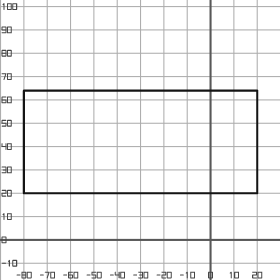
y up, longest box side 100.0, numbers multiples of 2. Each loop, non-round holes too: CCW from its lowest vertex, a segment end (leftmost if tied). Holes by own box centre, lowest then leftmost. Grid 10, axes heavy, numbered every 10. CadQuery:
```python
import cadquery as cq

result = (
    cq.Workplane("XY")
    .moveTo(-80.0, 20.0)
    .lineTo(20.0, 20.0)
    .lineTo(20.0, 64.0)
    .lineTo(-80.0, 64.0)
    .close()
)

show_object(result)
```